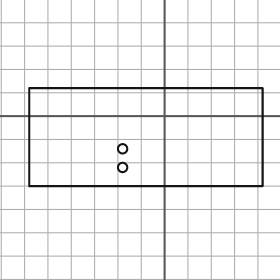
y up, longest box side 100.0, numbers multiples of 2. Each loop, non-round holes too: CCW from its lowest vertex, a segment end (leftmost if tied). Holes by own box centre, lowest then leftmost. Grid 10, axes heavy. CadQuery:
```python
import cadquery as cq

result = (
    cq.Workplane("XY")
    .moveTo(-58.0, -30.0)
    .lineTo(42.0, -30.0)
    .lineTo(42.0, 12.0)
    .lineTo(-58.0, 12.0)
    .close()
    .moveTo(-18.0, -22.0)
    .circle(2.0)
    .moveTo(-18.0, -14.0)
    .circle(2.0)
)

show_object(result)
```